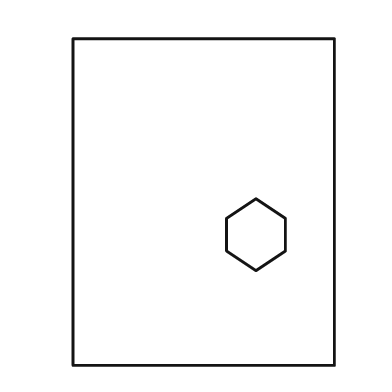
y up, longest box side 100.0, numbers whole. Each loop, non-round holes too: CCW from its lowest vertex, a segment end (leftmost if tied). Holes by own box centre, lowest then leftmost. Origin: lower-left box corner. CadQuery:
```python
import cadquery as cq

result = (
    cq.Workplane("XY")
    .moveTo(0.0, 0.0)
    .lineTo(80.0, 0.0)
    .lineTo(80.0, 100.0)
    .lineTo(0.0, 100.0)
    .close()
    .moveTo(56.0, 29.0)
    .lineTo(65.0, 35.0)
    .lineTo(65.0, 45.0)
    .lineTo(56.0, 51.0)
    .lineTo(47.0, 45.0)
    .lineTo(47.0, 35.0)
    .close()
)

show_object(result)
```